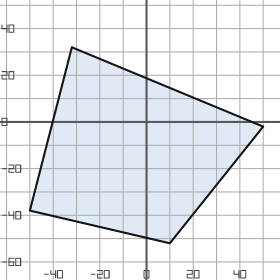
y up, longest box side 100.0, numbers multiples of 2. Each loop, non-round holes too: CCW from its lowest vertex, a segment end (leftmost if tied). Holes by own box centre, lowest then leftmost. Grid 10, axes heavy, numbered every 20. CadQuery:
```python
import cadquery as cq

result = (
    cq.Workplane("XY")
    .moveTo(10.0, -52.0)
    .lineTo(50.0, -2.0)
    .lineTo(-32.0, 32.0)
    .lineTo(-50.0, -38.0)
    .close()
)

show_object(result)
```